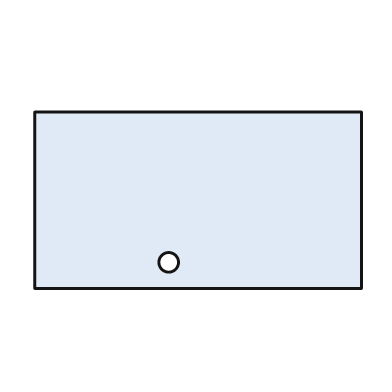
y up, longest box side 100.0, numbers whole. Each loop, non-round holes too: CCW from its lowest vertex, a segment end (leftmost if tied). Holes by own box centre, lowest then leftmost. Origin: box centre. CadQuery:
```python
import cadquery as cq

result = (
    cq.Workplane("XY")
    .moveTo(-50.0, -27.0)
    .lineTo(50.0, -27.0)
    .lineTo(50.0, 27.0)
    .lineTo(-50.0, 27.0)
    .close()
    .moveTo(-9.0, -19.0)
    .circle(3.0)
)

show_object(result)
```